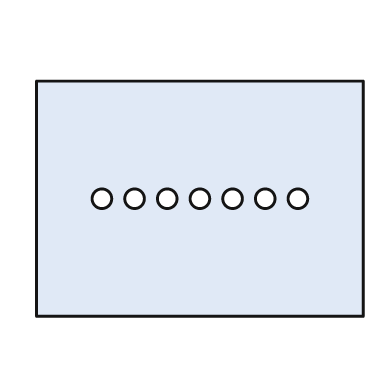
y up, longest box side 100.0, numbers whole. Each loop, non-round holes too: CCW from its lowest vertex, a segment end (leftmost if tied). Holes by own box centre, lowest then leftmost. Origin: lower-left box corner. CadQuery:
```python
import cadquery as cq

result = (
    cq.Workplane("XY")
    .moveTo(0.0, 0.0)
    .lineTo(100.0, 0.0)
    .lineTo(100.0, 72.0)
    .lineTo(0.0, 72.0)
    .close()
    .moveTo(20.0, 36.0)
    .circle(3.0)
    .moveTo(30.0, 36.0)
    .circle(3.0)
    .moveTo(40.0, 36.0)
    .circle(3.0)
    .moveTo(50.0, 36.0)
    .circle(3.0)
    .moveTo(60.0, 36.0)
    .circle(3.0)
    .moveTo(70.0, 36.0)
    .circle(3.0)
    .moveTo(80.0, 36.0)
    .circle(3.0)
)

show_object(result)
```